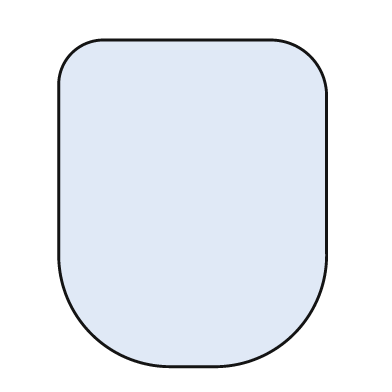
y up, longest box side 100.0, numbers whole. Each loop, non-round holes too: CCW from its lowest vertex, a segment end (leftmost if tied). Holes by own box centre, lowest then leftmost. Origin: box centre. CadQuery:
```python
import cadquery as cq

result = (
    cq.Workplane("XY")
    .moveTo(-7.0, -50.0)
    .lineTo(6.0, -50.0)
    .threePointArc((31.0, -40.0), (41.0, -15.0))
    .lineTo(41.0, 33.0)
    .threePointArc((36.0, 45.0), (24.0, 50.0))
    .lineTo(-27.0, 50.0)
    .threePointArc((-37.0, 46.0), (-41.0, 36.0))
    .lineTo(-41.0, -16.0)
    .threePointArc((-31.0, -40.0), (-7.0, -50.0))
    .close()
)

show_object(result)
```